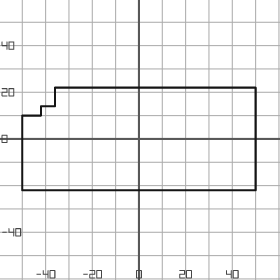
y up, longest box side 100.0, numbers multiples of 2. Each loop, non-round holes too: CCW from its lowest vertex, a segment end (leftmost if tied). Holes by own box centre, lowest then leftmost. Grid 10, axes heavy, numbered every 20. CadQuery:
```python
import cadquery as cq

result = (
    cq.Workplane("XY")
    .moveTo(-50.0, -22.0)
    .lineTo(50.0, -22.0)
    .lineTo(50.0, 22.0)
    .lineTo(-36.0, 22.0)
    .lineTo(-36.0, 14.0)
    .lineTo(-42.0, 14.0)
    .lineTo(-42.0, 10.0)
    .lineTo(-50.0, 10.0)
    .close()
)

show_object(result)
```